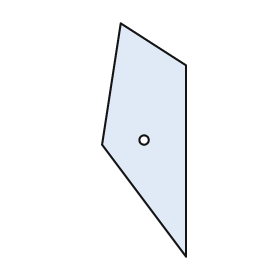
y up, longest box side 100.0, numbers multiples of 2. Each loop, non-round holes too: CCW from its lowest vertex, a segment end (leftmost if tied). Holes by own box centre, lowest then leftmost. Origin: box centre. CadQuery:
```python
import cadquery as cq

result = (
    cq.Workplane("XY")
    .moveTo(18.0, -50.0)
    .lineTo(18.0, 32.0)
    .lineTo(-10.0, 50.0)
    .lineTo(-18.0, -2.0)
    .close()
    .moveTo(0.0, 0.0)
    .circle(2.0)
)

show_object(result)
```